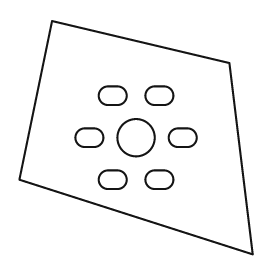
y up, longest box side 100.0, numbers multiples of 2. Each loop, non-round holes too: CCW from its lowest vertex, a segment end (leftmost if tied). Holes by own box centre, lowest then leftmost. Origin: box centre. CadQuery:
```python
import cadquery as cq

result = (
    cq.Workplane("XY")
    .moveTo(50.0, -50.0)
    .lineTo(40.0, 32.0)
    .lineTo(-36.0, 50.0)
    .lineTo(-50.0, -18.0)
    .close()
    .moveTo(-12.0, -22.0)
    .lineTo(-8.0, -22.0)
    .threePointArc((-4.0, -18.0), (-8.0, -14.0))
    .lineTo(-12.0, -14.0)
    .threePointArc((-16.0, -18.0), (-12.0, -22.0))
    .close()
    .moveTo(8.0, -22.0)
    .lineTo(12.0, -22.0)
    .threePointArc((16.0, -18.0), (12.0, -14.0))
    .lineTo(8.0, -14.0)
    .threePointArc((4.0, -18.0), (8.0, -22.0))
    .close()
    .moveTo(-22.0, -4.0)
    .lineTo(-18.0, -4.0)
    .threePointArc((-14.0, 0.0), (-18.0, 4.0))
    .lineTo(-22.0, 4.0)
    .threePointArc((-26.0, 0.0), (-22.0, -4.0))
    .close()
    .moveTo(0.0, 0.0)
    .circle(8.0)
    .moveTo(18.0, -4.0)
    .lineTo(22.0, -4.0)
    .threePointArc((26.0, 0.0), (22.0, 4.0))
    .lineTo(18.0, 4.0)
    .threePointArc((14.0, 0.0), (18.0, -4.0))
    .close()
    .moveTo(-12.0, 14.0)
    .lineTo(-8.0, 14.0)
    .threePointArc((-4.0, 18.0), (-8.0, 22.0))
    .lineTo(-12.0, 22.0)
    .threePointArc((-16.0, 18.0), (-12.0, 14.0))
    .close()
    .moveTo(8.0, 14.0)
    .lineTo(12.0, 14.0)
    .threePointArc((16.0, 18.0), (12.0, 22.0))
    .lineTo(8.0, 22.0)
    .threePointArc((4.0, 18.0), (8.0, 14.0))
    .close()
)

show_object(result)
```